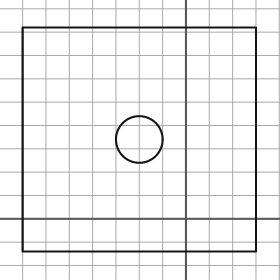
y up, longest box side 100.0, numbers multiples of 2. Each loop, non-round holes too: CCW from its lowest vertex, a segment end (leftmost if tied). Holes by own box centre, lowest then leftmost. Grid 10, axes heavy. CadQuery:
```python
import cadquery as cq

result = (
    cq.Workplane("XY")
    .moveTo(-70.0, -14.0)
    .lineTo(30.0, -14.0)
    .lineTo(30.0, 82.0)
    .lineTo(-70.0, 82.0)
    .close()
    .moveTo(-20.0, 34.0)
    .circle(10.0)
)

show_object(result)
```